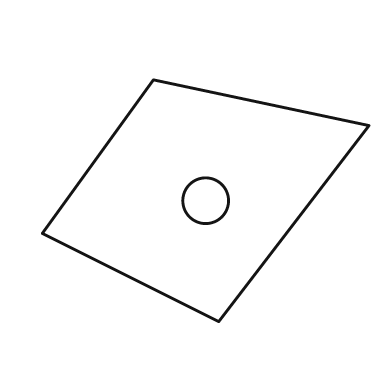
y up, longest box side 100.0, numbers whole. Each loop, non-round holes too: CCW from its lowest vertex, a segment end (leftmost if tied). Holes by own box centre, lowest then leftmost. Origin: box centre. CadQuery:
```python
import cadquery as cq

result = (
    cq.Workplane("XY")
    .moveTo(4.0, -37.0)
    .lineTo(50.0, 23.0)
    .lineTo(-16.0, 37.0)
    .lineTo(-50.0, -10.0)
    .close()
    .moveTo(0.0, 0.0)
    .circle(7.0)
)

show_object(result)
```